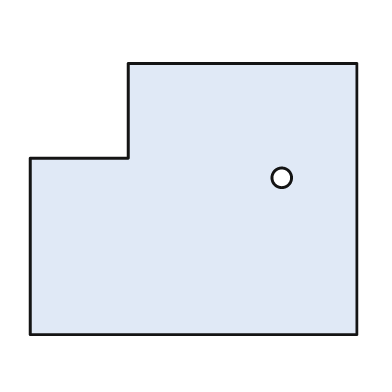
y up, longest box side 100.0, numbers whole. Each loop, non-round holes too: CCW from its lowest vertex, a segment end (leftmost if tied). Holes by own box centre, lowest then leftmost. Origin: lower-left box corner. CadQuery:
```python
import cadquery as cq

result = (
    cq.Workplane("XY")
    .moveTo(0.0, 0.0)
    .lineTo(100.0, 0.0)
    .lineTo(100.0, 83.0)
    .lineTo(30.0, 83.0)
    .lineTo(30.0, 54.0)
    .lineTo(0.0, 54.0)
    .close()
    .moveTo(77.0, 48.0)
    .circle(3.0)
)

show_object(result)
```